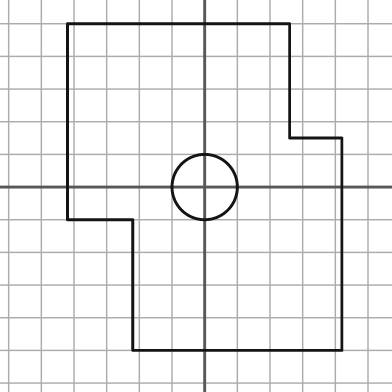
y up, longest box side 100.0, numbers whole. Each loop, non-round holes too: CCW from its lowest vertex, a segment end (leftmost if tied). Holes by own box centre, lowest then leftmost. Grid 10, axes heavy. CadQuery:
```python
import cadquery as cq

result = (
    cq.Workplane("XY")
    .moveTo(-22.0, -50.0)
    .lineTo(42.0, -50.0)
    .lineTo(42.0, 15.0)
    .lineTo(26.0, 15.0)
    .lineTo(26.0, 50.0)
    .lineTo(-42.0, 50.0)
    .lineTo(-42.0, -10.0)
    .lineTo(-22.0, -10.0)
    .close()
    .moveTo(0.0, 0.0)
    .circle(10.0)
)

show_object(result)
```